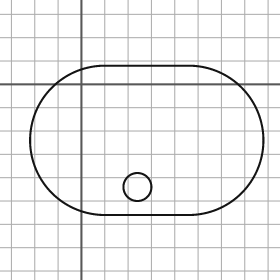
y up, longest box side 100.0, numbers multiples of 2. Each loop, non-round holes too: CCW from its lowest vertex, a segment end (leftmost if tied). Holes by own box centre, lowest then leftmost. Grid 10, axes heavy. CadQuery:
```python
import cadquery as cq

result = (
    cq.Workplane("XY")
    .moveTo(10.0, -56.0)
    .lineTo(46.0, -56.0)
    .threePointArc((78.0, -24.0), (46.0, 8.0))
    .lineTo(10.0, 8.0)
    .threePointArc((-22.0, -24.0), (10.0, -56.0))
    .close()
    .moveTo(24.0, -44.0)
    .circle(6.0)
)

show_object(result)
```